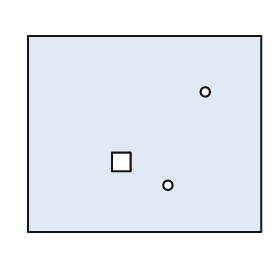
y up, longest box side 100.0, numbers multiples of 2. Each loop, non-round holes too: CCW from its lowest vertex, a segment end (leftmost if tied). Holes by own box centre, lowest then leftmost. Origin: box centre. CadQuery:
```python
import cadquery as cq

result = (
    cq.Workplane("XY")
    .moveTo(-50.0, -42.0)
    .lineTo(50.0, -42.0)
    .lineTo(50.0, 42.0)
    .lineTo(-50.0, 42.0)
    .close()
    .moveTo(10.0, -22.0)
    .circle(2.0)
    .moveTo(-14.0, -16.0)
    .lineTo(-6.0, -16.0)
    .lineTo(-6.0, -8.0)
    .lineTo(-14.0, -8.0)
    .close()
    .moveTo(26.0, 18.0)
    .circle(2.0)
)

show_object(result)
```